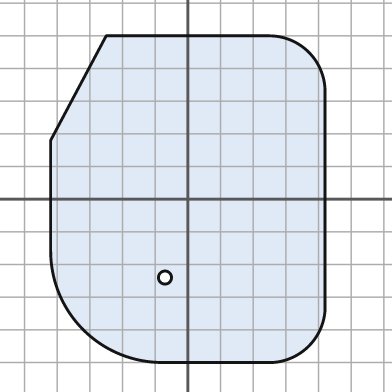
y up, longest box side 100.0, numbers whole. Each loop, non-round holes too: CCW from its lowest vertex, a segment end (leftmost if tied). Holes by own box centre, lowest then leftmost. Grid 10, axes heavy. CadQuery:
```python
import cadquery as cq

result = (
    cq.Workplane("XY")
    .moveTo(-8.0, -50.0)
    .lineTo(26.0, -50.0)
    .threePointArc((37.0, -45.0), (42.0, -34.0))
    .lineTo(42.0, 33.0)
    .threePointArc((37.0, 45.0), (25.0, 50.0))
    .lineTo(-25.0, 50.0)
    .lineTo(-42.0, 18.0)
    .lineTo(-42.0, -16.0)
    .threePointArc((-32.0, -40.0), (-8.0, -50.0))
    .close()
    .moveTo(-7.0, -24.0)
    .circle(2.0)
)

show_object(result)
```